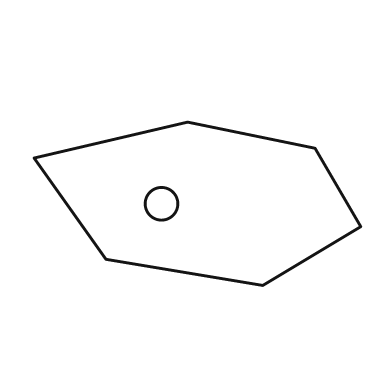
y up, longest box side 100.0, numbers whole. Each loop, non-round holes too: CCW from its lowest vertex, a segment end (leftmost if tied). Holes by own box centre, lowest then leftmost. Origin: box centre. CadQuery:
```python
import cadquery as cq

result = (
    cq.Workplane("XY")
    .moveTo(20.0, -25.0)
    .lineTo(50.0, -7.0)
    .lineTo(36.0, 17.0)
    .lineTo(-3.0, 25.0)
    .lineTo(-50.0, 14.0)
    .lineTo(-28.0, -17.0)
    .close()
    .moveTo(-11.0, 0.0)
    .circle(5.0)
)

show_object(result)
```